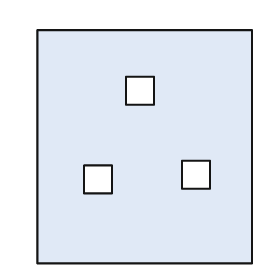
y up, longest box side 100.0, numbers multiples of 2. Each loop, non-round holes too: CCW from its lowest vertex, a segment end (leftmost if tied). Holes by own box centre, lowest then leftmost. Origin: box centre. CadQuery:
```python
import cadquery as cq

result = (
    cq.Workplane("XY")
    .moveTo(-46.0, -50.0)
    .lineTo(46.0, -50.0)
    .lineTo(46.0, 50.0)
    .lineTo(-46.0, 50.0)
    .close()
    .moveTo(-26.0, -20.0)
    .lineTo(-14.0, -20.0)
    .lineTo(-14.0, -8.0)
    .lineTo(-26.0, -8.0)
    .close()
    .moveTo(16.0, -18.0)
    .lineTo(28.0, -18.0)
    .lineTo(28.0, -6.0)
    .lineTo(16.0, -6.0)
    .close()
    .moveTo(-8.0, 18.0)
    .lineTo(4.0, 18.0)
    .lineTo(4.0, 30.0)
    .lineTo(-8.0, 30.0)
    .close()
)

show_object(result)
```